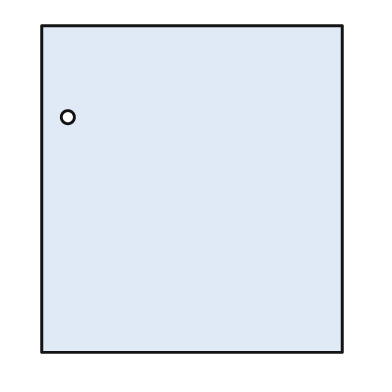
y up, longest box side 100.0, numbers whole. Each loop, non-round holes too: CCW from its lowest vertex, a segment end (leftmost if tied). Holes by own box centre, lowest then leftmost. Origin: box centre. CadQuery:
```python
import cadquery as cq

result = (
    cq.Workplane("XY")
    .moveTo(-46.0, -50.0)
    .lineTo(46.0, -50.0)
    .lineTo(46.0, 50.0)
    .lineTo(-46.0, 50.0)
    .close()
    .moveTo(-38.0, 22.0)
    .circle(2.0)
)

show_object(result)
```